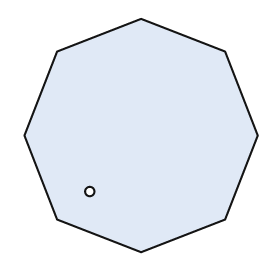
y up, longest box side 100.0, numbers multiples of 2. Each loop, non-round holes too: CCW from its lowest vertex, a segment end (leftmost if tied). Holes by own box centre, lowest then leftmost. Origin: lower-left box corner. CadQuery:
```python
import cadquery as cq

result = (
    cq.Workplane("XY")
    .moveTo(50.0, 0.0)
    .lineTo(86.0, 14.0)
    .lineTo(100.0, 50.0)
    .lineTo(86.0, 86.0)
    .lineTo(50.0, 100.0)
    .lineTo(14.0, 86.0)
    .lineTo(0.0, 50.0)
    .lineTo(14.0, 14.0)
    .close()
    .moveTo(28.0, 26.0)
    .circle(2.0)
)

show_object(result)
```